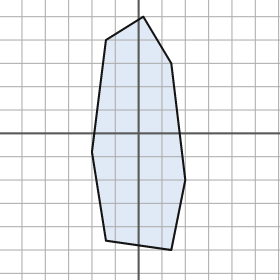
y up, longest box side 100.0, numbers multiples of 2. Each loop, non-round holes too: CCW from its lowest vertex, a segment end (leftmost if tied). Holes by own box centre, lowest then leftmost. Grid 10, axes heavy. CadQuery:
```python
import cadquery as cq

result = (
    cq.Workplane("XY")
    .moveTo(14.0, -50.0)
    .lineTo(20.0, -20.0)
    .lineTo(14.0, 30.0)
    .lineTo(2.0, 50.0)
    .lineTo(-14.0, 40.0)
    .lineTo(-20.0, -8.0)
    .lineTo(-14.0, -46.0)
    .close()
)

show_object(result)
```